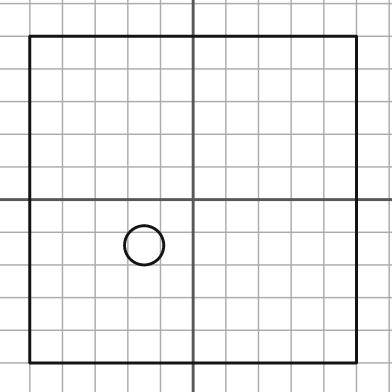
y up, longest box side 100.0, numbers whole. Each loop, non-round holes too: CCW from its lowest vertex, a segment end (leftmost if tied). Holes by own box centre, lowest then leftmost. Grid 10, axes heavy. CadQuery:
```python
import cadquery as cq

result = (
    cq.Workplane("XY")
    .moveTo(-50.0, -50.0)
    .lineTo(50.0, -50.0)
    .lineTo(50.0, 50.0)
    .lineTo(-50.0, 50.0)
    .close()
    .moveTo(-15.0, -14.0)
    .circle(6.0)
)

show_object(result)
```